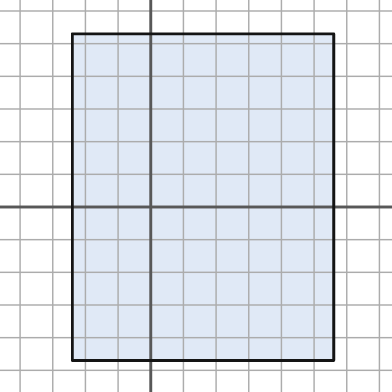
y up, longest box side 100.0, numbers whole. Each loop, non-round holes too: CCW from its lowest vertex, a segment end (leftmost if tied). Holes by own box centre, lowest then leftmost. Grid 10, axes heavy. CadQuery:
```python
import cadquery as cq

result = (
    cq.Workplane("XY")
    .moveTo(-24.0, -47.0)
    .lineTo(56.0, -47.0)
    .lineTo(56.0, 53.0)
    .lineTo(-24.0, 53.0)
    .close()
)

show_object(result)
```